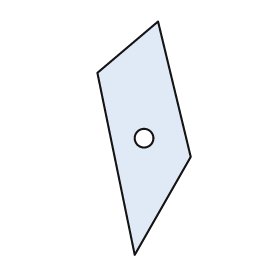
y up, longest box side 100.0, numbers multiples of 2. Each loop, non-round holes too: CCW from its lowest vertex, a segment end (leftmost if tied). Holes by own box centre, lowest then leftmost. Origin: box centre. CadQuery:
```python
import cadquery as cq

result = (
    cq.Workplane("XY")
    .moveTo(-4.0, -50.0)
    .lineTo(20.0, -8.0)
    .lineTo(6.0, 50.0)
    .lineTo(-20.0, 28.0)
    .close()
    .moveTo(0.0, 0.0)
    .circle(4.0)
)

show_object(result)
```